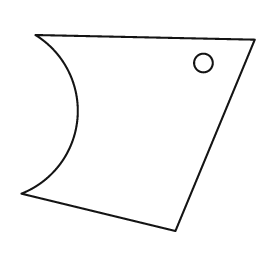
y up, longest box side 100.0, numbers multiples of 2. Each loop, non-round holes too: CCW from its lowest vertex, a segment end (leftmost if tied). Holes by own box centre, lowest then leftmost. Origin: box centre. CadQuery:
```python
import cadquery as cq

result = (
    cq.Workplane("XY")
    .moveTo(16.0, -42.0)
    .lineTo(50.0, 40.0)
    .lineTo(-44.0, 42.0)
    .threePointArc((-26.0, 6.0), (-50.0, -26.0))
    .close()
    .moveTo(28.0, 30.0)
    .circle(4.0)
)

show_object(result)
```